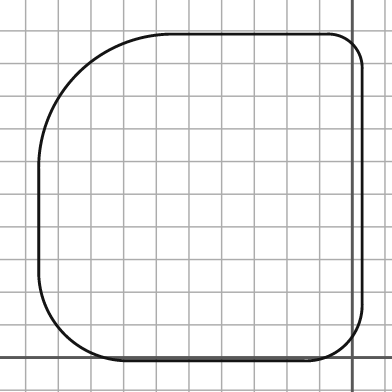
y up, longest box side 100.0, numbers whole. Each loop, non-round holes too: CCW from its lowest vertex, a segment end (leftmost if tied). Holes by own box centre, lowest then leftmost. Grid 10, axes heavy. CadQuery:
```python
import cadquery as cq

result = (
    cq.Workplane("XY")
    .moveTo(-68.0, -1.0)
    .lineTo(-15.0, -1.0)
    .threePointArc((-2.0, 4.0), (3.0, 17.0))
    .lineTo(3.0, 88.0)
    .threePointArc((0.0, 96.0), (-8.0, 99.0))
    .lineTo(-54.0, 99.0)
    .threePointArc((-84.0, 87.0), (-96.0, 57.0))
    .lineTo(-96.0, 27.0)
    .threePointArc((-88.0, 7.0), (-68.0, -1.0))
    .close()
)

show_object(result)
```